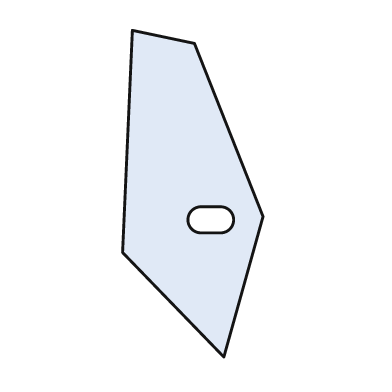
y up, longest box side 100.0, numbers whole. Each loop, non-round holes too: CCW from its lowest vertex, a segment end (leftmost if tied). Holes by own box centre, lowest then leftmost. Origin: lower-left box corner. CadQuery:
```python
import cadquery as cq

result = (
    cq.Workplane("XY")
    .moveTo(31.0, 0.0)
    .lineTo(43.0, 43.0)
    .lineTo(22.0, 96.0)
    .lineTo(3.0, 100.0)
    .lineTo(0.0, 32.0)
    .close()
    .moveTo(24.0, 38.0)
    .lineTo(30.0, 38.0)
    .threePointArc((34.0, 42.0), (30.0, 46.0))
    .lineTo(24.0, 46.0)
    .threePointArc((20.0, 42.0), (24.0, 38.0))
    .close()
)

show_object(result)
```